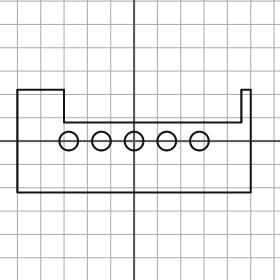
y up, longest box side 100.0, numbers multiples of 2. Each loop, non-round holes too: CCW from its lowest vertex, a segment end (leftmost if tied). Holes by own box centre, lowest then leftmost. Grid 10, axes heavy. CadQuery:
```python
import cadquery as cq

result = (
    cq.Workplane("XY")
    .moveTo(-50.0, -22.0)
    .lineTo(50.0, -22.0)
    .lineTo(50.0, 22.0)
    .lineTo(46.0, 22.0)
    .lineTo(46.0, 8.0)
    .lineTo(-30.0, 8.0)
    .lineTo(-30.0, 22.0)
    .lineTo(-50.0, 22.0)
    .close()
    .moveTo(-28.0, 0.0)
    .circle(4.0)
    .moveTo(-14.0, 0.0)
    .circle(4.0)
    .moveTo(0.0, 0.0)
    .circle(4.0)
    .moveTo(14.0, 0.0)
    .circle(4.0)
    .moveTo(28.0, 0.0)
    .circle(4.0)
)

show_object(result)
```